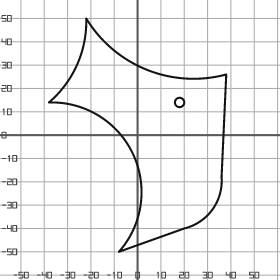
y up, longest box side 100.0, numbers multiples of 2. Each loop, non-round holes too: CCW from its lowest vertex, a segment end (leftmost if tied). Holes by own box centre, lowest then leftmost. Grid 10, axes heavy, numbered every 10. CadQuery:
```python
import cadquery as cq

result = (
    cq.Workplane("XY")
    .moveTo(-8.0, -50.0)
    .lineTo(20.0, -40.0)
    .threePointArc((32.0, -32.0), (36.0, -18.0))
    .lineTo(38.0, 26.0)
    .threePointArc((4.0, 28.0), (-22.0, 50.0))
    .threePointArc((-26.0, 30.0), (-38.0, 14.0))
    .threePointArc((-2.0, -8.0), (-8.0, -50.0))
    .close()
    .moveTo(18.0, 14.0)
    .circle(2.0)
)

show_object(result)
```